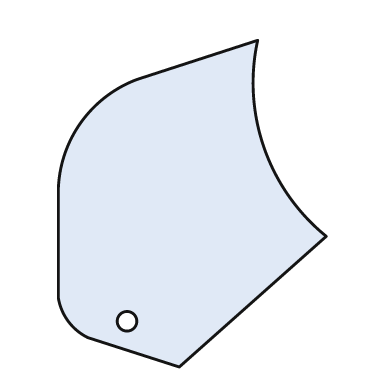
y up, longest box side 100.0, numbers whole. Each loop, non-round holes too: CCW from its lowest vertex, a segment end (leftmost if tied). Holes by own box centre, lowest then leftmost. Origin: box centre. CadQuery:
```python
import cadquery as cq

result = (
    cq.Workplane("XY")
    .moveTo(-4.0, -50.0)
    .lineTo(41.0, -10.0)
    .threePointArc((22.0, 17.0), (20.0, 50.0))
    .lineTo(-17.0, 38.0)
    .threePointArc((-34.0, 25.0), (-41.0, 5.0))
    .lineTo(-41.0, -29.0)
    .threePointArc((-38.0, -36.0), (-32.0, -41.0))
    .close()
    .moveTo(-20.0, -36.0)
    .circle(3.0)
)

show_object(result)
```